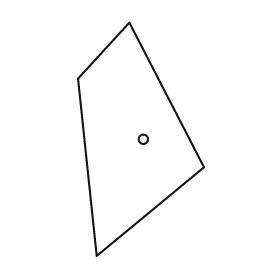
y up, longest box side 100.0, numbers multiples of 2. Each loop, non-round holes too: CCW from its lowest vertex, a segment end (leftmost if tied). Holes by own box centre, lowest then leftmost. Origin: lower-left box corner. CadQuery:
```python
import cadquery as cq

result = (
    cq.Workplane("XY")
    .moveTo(8.0, 0.0)
    .lineTo(54.0, 38.0)
    .lineTo(22.0, 100.0)
    .lineTo(0.0, 76.0)
    .close()
    .moveTo(28.0, 50.0)
    .circle(2.0)
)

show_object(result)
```